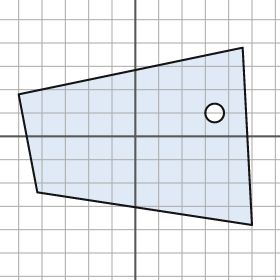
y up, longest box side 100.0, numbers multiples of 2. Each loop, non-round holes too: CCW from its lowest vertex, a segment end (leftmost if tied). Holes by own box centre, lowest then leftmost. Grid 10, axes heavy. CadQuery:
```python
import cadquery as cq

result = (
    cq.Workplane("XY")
    .moveTo(50.0, -38.0)
    .lineTo(46.0, 38.0)
    .lineTo(-50.0, 18.0)
    .lineTo(-42.0, -24.0)
    .close()
    .moveTo(34.0, 10.0)
    .circle(4.0)
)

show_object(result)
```